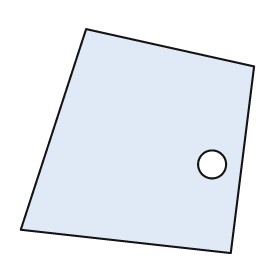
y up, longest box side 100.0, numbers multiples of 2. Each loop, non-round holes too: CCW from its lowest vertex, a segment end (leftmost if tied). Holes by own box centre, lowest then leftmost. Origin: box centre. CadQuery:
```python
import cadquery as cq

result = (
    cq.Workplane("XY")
    .moveTo(40.0, -48.0)
    .lineTo(50.0, 32.0)
    .lineTo(-22.0, 48.0)
    .lineTo(-50.0, -38.0)
    .close()
    .moveTo(32.0, -10.0)
    .circle(6.0)
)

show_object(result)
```